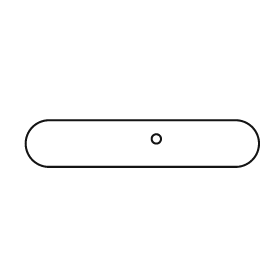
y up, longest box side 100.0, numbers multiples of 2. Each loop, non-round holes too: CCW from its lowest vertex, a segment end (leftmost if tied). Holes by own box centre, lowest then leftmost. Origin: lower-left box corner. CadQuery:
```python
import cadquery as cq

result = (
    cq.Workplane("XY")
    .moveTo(10.0, 0.0)
    .lineTo(90.0, 0.0)
    .threePointArc((100.0, 10.0), (90.0, 20.0))
    .lineTo(10.0, 20.0)
    .threePointArc((0.0, 10.0), (10.0, 0.0))
    .close()
    .moveTo(56.0, 12.0)
    .circle(2.0)
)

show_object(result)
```